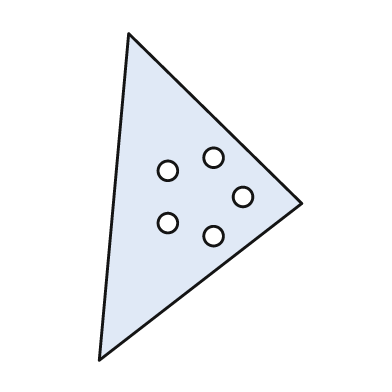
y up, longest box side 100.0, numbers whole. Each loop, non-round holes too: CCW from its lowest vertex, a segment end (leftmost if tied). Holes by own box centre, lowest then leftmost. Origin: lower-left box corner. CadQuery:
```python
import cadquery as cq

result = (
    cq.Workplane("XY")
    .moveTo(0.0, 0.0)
    .lineTo(62.0, 48.0)
    .lineTo(9.0, 100.0)
    .close()
    .moveTo(35.0, 38.0)
    .circle(3.0)
    .moveTo(21.0, 42.0)
    .circle(3.0)
    .moveTo(44.0, 50.0)
    .circle(3.0)
    .moveTo(21.0, 58.0)
    .circle(3.0)
    .moveTo(35.0, 62.0)
    .circle(3.0)
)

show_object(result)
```